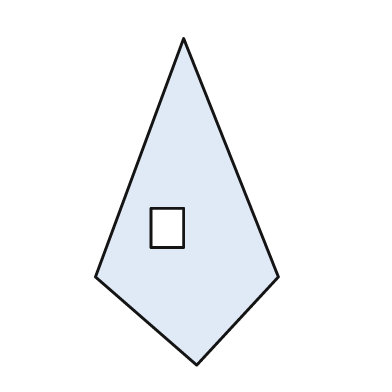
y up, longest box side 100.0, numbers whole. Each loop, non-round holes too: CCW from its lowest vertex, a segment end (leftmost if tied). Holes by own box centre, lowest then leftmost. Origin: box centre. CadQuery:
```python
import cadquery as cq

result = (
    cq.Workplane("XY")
    .moveTo(3.0, -50.0)
    .lineTo(28.0, -23.0)
    .lineTo(-1.0, 50.0)
    .lineTo(-28.0, -23.0)
    .close()
    .moveTo(-11.0, -14.0)
    .lineTo(-1.0, -14.0)
    .lineTo(-1.0, -2.0)
    .lineTo(-11.0, -2.0)
    .close()
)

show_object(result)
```